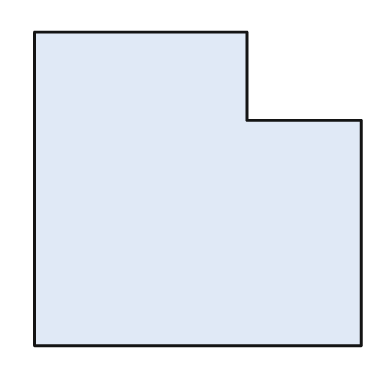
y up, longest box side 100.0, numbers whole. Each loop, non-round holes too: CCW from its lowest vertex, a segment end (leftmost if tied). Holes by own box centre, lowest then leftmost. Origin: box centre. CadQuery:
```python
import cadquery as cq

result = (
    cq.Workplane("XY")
    .moveTo(-50.0, -48.0)
    .lineTo(50.0, -48.0)
    .lineTo(50.0, 21.0)
    .lineTo(15.0, 21.0)
    .lineTo(15.0, 48.0)
    .lineTo(-50.0, 48.0)
    .close()
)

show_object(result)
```